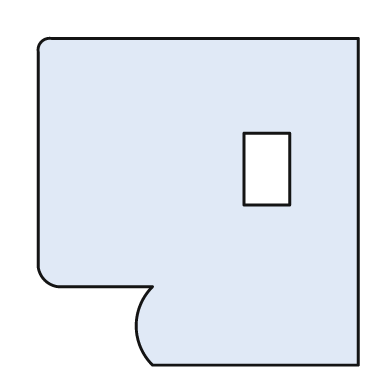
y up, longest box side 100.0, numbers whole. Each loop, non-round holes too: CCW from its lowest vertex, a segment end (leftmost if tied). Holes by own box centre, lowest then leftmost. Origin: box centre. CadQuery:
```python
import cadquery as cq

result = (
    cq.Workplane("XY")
    .moveTo(-14.0, -50.0)
    .lineTo(49.0, -50.0)
    .lineTo(49.0, 50.0)
    .lineTo(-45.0, 50.0)
    .threePointArc((-48.0, 49.0), (-49.0, 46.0))
    .lineTo(-49.0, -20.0)
    .threePointArc((-47.0, -24.0), (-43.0, -26.0))
    .lineTo(-14.0, -26.0)
    .threePointArc((-19.0, -38.0), (-14.0, -50.0))
    .close()
    .moveTo(14.0, -1.0)
    .lineTo(28.0, -1.0)
    .lineTo(28.0, 21.0)
    .lineTo(14.0, 21.0)
    .close()
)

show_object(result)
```